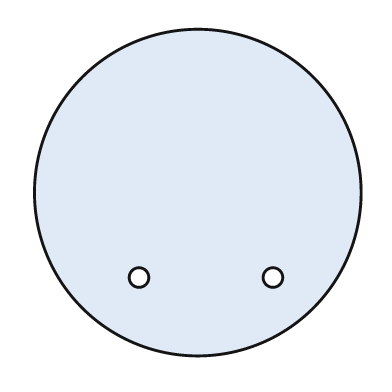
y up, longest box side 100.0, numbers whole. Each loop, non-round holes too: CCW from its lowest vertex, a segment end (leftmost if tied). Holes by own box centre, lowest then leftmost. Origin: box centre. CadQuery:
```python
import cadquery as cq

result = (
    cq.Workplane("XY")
    .moveTo(0.0, 0.0)
    .circle(50.0)
    .moveTo(-18.0, -26.0)
    .circle(3.0)
    .moveTo(23.0, -26.0)
    .circle(3.0)
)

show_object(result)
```